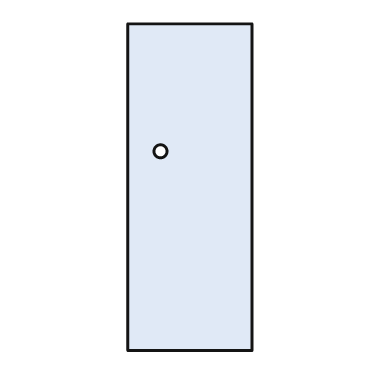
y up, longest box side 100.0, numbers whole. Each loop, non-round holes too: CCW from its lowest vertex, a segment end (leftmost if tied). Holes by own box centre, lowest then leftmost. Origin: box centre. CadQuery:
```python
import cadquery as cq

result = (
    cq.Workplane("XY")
    .moveTo(-19.0, -50.0)
    .lineTo(19.0, -50.0)
    .lineTo(19.0, 50.0)
    .lineTo(-19.0, 50.0)
    .close()
    .moveTo(-9.0, 11.0)
    .circle(2.0)
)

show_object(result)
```